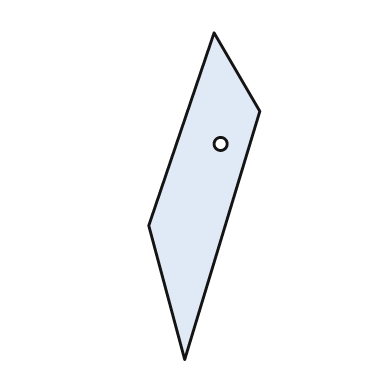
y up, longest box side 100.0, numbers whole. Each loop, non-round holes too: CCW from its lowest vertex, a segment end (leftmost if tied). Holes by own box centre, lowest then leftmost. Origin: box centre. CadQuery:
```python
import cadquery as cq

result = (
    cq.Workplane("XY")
    .moveTo(-6.0, -50.0)
    .lineTo(17.0, 26.0)
    .lineTo(3.0, 50.0)
    .lineTo(-17.0, -9.0)
    .close()
    .moveTo(5.0, 16.0)
    .circle(2.0)
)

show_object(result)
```